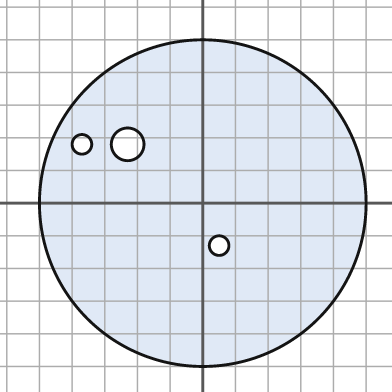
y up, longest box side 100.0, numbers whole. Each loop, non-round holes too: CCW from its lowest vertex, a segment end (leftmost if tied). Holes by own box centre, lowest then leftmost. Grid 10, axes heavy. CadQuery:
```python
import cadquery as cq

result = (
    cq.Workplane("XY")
    .moveTo(0.0, 0.0)
    .circle(50.0)
    .moveTo(5.0, -13.0)
    .circle(3.0)
    .moveTo(-37.0, 18.0)
    .circle(3.0)
    .moveTo(-23.0, 18.0)
    .circle(5.0)
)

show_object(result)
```